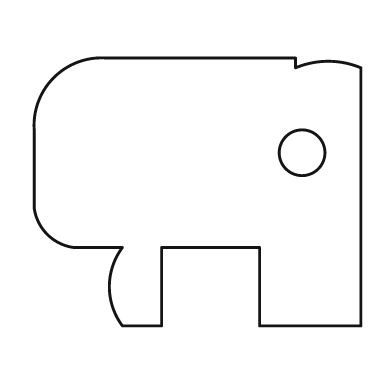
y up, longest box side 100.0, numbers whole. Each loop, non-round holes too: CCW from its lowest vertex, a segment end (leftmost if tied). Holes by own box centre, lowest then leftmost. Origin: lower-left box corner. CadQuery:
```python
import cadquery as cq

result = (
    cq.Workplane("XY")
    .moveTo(27.0, 0.0)
    .lineTo(39.0, 0.0)
    .lineTo(39.0, 24.0)
    .lineTo(69.0, 24.0)
    .lineTo(69.0, 0.0)
    .lineTo(100.0, 0.0)
    .lineTo(100.0, 79.0)
    .threePointArc((90.0, 81.0), (80.0, 79.0))
    .lineTo(80.0, 82.0)
    .lineTo(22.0, 82.0)
    .threePointArc((6.0, 76.0), (0.0, 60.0))
    .lineTo(0.0, 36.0)
    .threePointArc((4.0, 28.0), (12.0, 24.0))
    .lineTo(27.0, 24.0)
    .threePointArc((23.0, 12.0), (27.0, 0.0))
    .close()
    .moveTo(82.0, 53.0)
    .circle(7.0)
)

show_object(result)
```